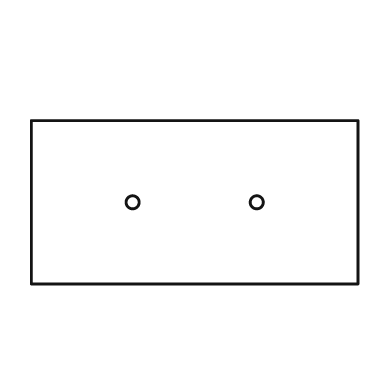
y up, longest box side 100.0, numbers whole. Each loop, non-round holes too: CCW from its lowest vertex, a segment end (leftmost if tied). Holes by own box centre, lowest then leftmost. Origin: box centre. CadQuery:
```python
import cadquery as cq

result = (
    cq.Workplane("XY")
    .moveTo(-50.0, -25.0)
    .lineTo(50.0, -25.0)
    .lineTo(50.0, 25.0)
    .lineTo(-50.0, 25.0)
    .close()
    .moveTo(-19.0, 0.0)
    .circle(2.0)
    .moveTo(19.0, 0.0)
    .circle(2.0)
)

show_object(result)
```